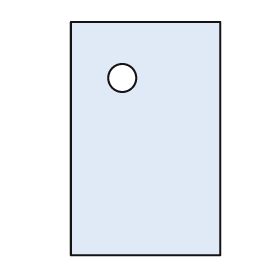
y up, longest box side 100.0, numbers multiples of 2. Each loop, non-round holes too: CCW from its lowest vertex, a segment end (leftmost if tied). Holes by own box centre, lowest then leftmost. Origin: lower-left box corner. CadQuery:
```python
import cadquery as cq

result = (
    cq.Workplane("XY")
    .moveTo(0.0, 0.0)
    .lineTo(64.0, 0.0)
    .lineTo(64.0, 100.0)
    .lineTo(0.0, 100.0)
    .close()
    .moveTo(22.0, 76.0)
    .circle(6.0)
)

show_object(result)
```